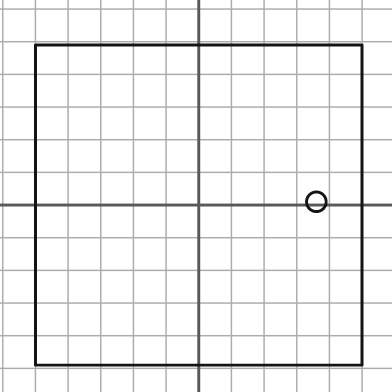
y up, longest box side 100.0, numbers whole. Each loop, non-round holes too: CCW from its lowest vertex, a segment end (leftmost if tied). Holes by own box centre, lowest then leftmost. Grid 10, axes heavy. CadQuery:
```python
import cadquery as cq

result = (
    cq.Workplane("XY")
    .moveTo(-50.0, -49.0)
    .lineTo(50.0, -49.0)
    .lineTo(50.0, 49.0)
    .lineTo(-50.0, 49.0)
    .close()
    .moveTo(36.0, 1.0)
    .circle(3.0)
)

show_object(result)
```